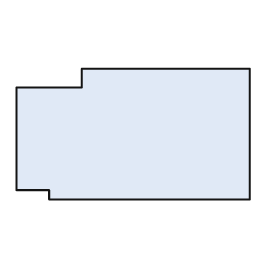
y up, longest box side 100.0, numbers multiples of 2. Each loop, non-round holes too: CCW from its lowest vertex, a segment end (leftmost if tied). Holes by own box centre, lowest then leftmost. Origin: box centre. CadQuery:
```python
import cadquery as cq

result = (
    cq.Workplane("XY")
    .moveTo(-36.0, -28.0)
    .lineTo(50.0, -28.0)
    .lineTo(50.0, 28.0)
    .lineTo(-22.0, 28.0)
    .lineTo(-22.0, 20.0)
    .lineTo(-50.0, 20.0)
    .lineTo(-50.0, -24.0)
    .lineTo(-36.0, -24.0)
    .close()
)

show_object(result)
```